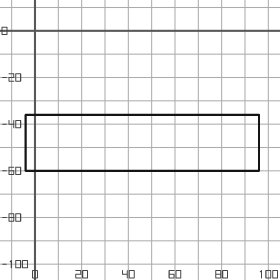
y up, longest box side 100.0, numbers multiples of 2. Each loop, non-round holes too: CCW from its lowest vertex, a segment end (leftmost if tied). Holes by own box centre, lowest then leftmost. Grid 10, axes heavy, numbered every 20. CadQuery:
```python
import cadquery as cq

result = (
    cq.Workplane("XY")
    .moveTo(-4.0, -60.0)
    .lineTo(96.0, -60.0)
    .lineTo(96.0, -36.0)
    .lineTo(-4.0, -36.0)
    .close()
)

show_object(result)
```